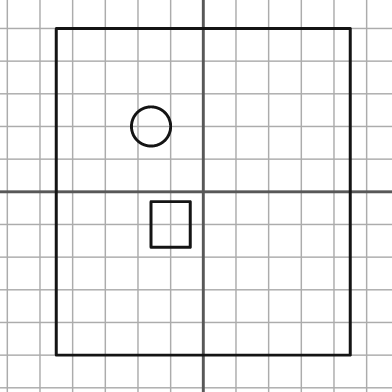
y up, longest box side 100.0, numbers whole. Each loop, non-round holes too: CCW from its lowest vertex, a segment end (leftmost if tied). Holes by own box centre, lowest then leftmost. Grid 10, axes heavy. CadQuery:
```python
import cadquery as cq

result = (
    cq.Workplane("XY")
    .moveTo(-45.0, -50.0)
    .lineTo(45.0, -50.0)
    .lineTo(45.0, 50.0)
    .lineTo(-45.0, 50.0)
    .close()
    .moveTo(-16.0, -17.0)
    .lineTo(-4.0, -17.0)
    .lineTo(-4.0, -3.0)
    .lineTo(-16.0, -3.0)
    .close()
    .moveTo(-16.0, 20.0)
    .circle(6.0)
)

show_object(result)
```